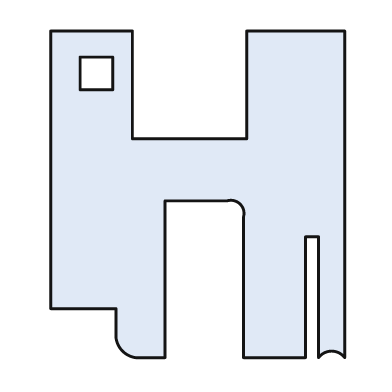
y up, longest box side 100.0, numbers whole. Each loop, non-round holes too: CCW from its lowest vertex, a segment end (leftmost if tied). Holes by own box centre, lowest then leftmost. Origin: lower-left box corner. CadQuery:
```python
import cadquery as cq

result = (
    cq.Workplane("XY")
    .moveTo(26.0, 0.0)
    .lineTo(35.0, 0.0)
    .lineTo(35.0, 48.0)
    .lineTo(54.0, 48.0)
    .threePointArc((58.0, 47.0), (59.0, 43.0))
    .lineTo(59.0, 0.0)
    .lineTo(78.0, 0.0)
    .lineTo(78.0, 37.0)
    .lineTo(82.0, 37.0)
    .lineTo(82.0, 0.0)
    .threePointArc((86.0, 2.0), (90.0, 0.0))
    .lineTo(90.0, 100.0)
    .lineTo(60.0, 100.0)
    .lineTo(60.0, 67.0)
    .lineTo(25.0, 67.0)
    .lineTo(25.0, 100.0)
    .lineTo(0.0, 100.0)
    .lineTo(0.0, 15.0)
    .lineTo(20.0, 15.0)
    .lineTo(20.0, 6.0)
    .threePointArc((22.0, 2.0), (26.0, 0.0))
    .close()
    .moveTo(9.0, 82.0)
    .lineTo(19.0, 82.0)
    .lineTo(19.0, 92.0)
    .lineTo(9.0, 92.0)
    .close()
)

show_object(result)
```